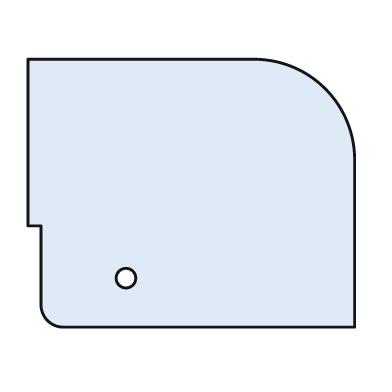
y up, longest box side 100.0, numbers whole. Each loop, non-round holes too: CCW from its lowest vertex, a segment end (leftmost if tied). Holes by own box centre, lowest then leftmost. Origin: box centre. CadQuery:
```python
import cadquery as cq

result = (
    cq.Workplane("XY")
    .moveTo(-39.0, -41.0)
    .lineTo(50.0, -41.0)
    .lineTo(50.0, 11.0)
    .threePointArc((41.0, 32.0), (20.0, 41.0))
    .lineTo(-50.0, 41.0)
    .lineTo(-50.0, -10.0)
    .lineTo(-46.0, -10.0)
    .lineTo(-46.0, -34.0)
    .threePointArc((-44.0, -39.0), (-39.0, -41.0))
    .close()
    .moveTo(-20.0, -26.0)
    .circle(3.0)
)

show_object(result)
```